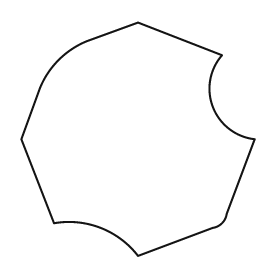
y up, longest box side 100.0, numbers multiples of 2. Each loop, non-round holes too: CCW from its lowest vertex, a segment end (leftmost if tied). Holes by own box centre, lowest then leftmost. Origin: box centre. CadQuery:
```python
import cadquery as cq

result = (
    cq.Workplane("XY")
    .moveTo(0.0, -50.0)
    .lineTo(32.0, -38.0)
    .threePointArc((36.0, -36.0), (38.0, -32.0))
    .lineTo(50.0, 0.0)
    .threePointArc((32.0, 14.0), (36.0, 36.0))
    .lineTo(0.0, 50.0)
    .lineTo(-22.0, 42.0)
    .threePointArc((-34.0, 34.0), (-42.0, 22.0))
    .lineTo(-50.0, 0.0)
    .lineTo(-36.0, -36.0)
    .threePointArc((-16.0, -38.0), (0.0, -50.0))
    .close()
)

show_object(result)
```